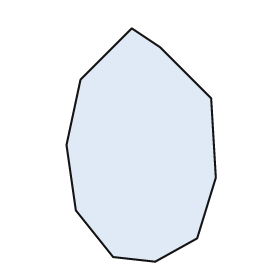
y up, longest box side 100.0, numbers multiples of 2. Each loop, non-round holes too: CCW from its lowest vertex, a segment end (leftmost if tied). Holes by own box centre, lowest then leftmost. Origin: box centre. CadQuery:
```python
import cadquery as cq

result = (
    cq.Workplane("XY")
    .moveTo(6.0, -50.0)
    .lineTo(24.0, -40.0)
    .lineTo(32.0, -14.0)
    .lineTo(30.0, 20.0)
    .lineTo(8.0, 42.0)
    .lineTo(-4.0, 50.0)
    .lineTo(-26.0, 28.0)
    .lineTo(-32.0, 0.0)
    .lineTo(-28.0, -28.0)
    .lineTo(-12.0, -48.0)
    .close()
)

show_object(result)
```